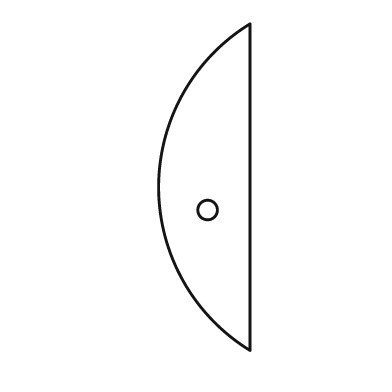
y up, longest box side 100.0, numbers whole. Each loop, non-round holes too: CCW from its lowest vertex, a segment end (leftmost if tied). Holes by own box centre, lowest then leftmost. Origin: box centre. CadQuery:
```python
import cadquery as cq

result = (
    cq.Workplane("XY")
    .moveTo(14.0, -50.0)
    .lineTo(14.0, 50.0)
    .threePointArc((-14.0, 0.0), (14.0, -50.0))
    .close()
    .moveTo(1.0, -7.0)
    .circle(3.0)
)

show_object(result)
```